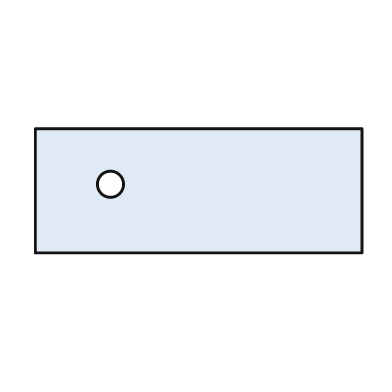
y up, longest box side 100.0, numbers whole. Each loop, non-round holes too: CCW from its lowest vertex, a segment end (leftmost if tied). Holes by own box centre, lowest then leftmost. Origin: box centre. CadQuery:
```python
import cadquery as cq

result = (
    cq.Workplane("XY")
    .moveTo(-50.0, -19.0)
    .lineTo(50.0, -19.0)
    .lineTo(50.0, 19.0)
    .lineTo(-50.0, 19.0)
    .close()
    .moveTo(-27.0, 2.0)
    .circle(4.0)
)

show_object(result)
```